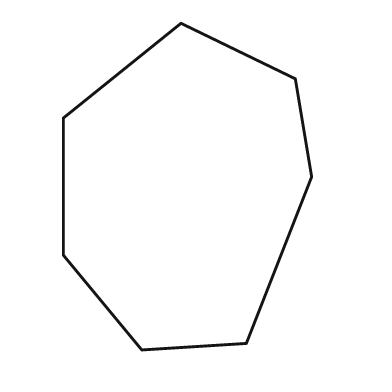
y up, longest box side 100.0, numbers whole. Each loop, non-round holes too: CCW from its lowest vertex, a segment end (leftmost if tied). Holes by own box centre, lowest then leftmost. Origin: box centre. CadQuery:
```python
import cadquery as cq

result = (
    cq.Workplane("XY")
    .moveTo(-14.0, -50.0)
    .lineTo(18.0, -48.0)
    .lineTo(38.0, 3.0)
    .lineTo(33.0, 33.0)
    .lineTo(-2.0, 50.0)
    .lineTo(-38.0, 21.0)
    .lineTo(-38.0, -21.0)
    .close()
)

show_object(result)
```